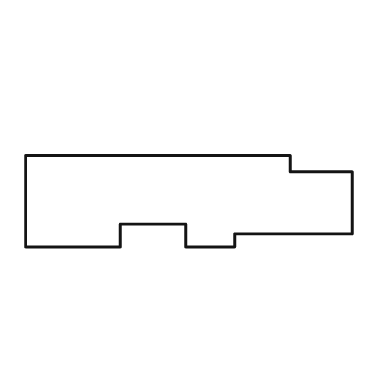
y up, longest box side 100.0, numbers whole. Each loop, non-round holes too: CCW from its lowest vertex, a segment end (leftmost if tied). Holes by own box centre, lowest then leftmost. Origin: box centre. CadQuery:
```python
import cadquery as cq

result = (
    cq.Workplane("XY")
    .moveTo(-50.0, -14.0)
    .lineTo(-21.0, -14.0)
    .lineTo(-21.0, -7.0)
    .lineTo(-1.0, -7.0)
    .lineTo(-1.0, -14.0)
    .lineTo(14.0, -14.0)
    .lineTo(14.0, -10.0)
    .lineTo(50.0, -10.0)
    .lineTo(50.0, 9.0)
    .lineTo(31.0, 9.0)
    .lineTo(31.0, 14.0)
    .lineTo(-50.0, 14.0)
    .close()
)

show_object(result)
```